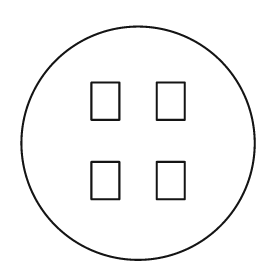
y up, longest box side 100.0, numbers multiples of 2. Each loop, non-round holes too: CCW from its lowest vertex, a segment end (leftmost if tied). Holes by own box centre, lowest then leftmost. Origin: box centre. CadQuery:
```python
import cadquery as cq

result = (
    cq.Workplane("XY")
    .moveTo(0.0, 0.0)
    .circle(50.0)
    .moveTo(-20.0, -24.0)
    .lineTo(-8.0, -24.0)
    .lineTo(-8.0, -8.0)
    .lineTo(-20.0, -8.0)
    .close()
    .moveTo(8.0, -24.0)
    .lineTo(20.0, -24.0)
    .lineTo(20.0, -8.0)
    .lineTo(8.0, -8.0)
    .close()
    .moveTo(-20.0, 10.0)
    .lineTo(-8.0, 10.0)
    .lineTo(-8.0, 26.0)
    .lineTo(-20.0, 26.0)
    .close()
    .moveTo(8.0, 10.0)
    .lineTo(20.0, 10.0)
    .lineTo(20.0, 26.0)
    .lineTo(8.0, 26.0)
    .close()
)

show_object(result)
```